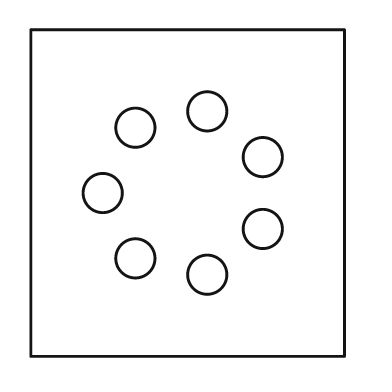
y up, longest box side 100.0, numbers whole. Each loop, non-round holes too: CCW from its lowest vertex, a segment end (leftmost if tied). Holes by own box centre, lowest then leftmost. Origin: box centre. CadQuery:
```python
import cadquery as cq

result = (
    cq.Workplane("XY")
    .moveTo(-48.0, -50.0)
    .lineTo(48.0, -50.0)
    .lineTo(48.0, 50.0)
    .lineTo(-48.0, 50.0)
    .close()
    .moveTo(6.0, -25.0)
    .circle(6.0)
    .moveTo(-16.0, -20.0)
    .circle(6.0)
    .moveTo(23.0, -11.0)
    .circle(6.0)
    .moveTo(-26.0, 0.0)
    .circle(6.0)
    .moveTo(23.0, 11.0)
    .circle(6.0)
    .moveTo(-16.0, 20.0)
    .circle(6.0)
    .moveTo(6.0, 25.0)
    .circle(6.0)
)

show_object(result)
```